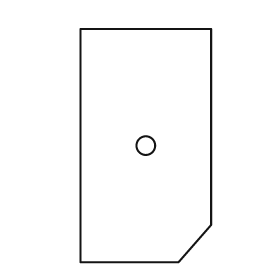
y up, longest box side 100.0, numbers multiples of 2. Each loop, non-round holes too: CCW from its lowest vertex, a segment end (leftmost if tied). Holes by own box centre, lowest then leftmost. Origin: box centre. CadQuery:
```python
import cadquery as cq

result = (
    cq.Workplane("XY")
    .moveTo(-28.0, -50.0)
    .lineTo(14.0, -50.0)
    .lineTo(28.0, -34.0)
    .lineTo(28.0, 50.0)
    .lineTo(-28.0, 50.0)
    .close()
    .moveTo(0.0, 0.0)
    .circle(4.0)
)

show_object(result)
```